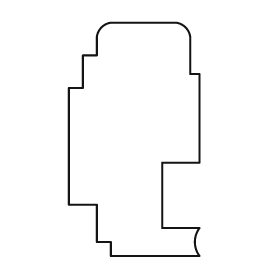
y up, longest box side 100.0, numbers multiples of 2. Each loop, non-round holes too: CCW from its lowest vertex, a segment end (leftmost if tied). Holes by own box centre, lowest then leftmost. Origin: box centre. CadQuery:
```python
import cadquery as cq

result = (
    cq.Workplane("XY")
    .moveTo(-10.0, -50.0)
    .lineTo(28.0, -50.0)
    .threePointArc((26.0, -44.0), (28.0, -38.0))
    .lineTo(12.0, -38.0)
    .lineTo(12.0, -10.0)
    .lineTo(28.0, -10.0)
    .lineTo(28.0, 28.0)
    .lineTo(24.0, 28.0)
    .lineTo(24.0, 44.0)
    .threePointArc((22.0, 48.0), (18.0, 50.0))
    .lineTo(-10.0, 50.0)
    .threePointArc((-14.0, 48.0), (-16.0, 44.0))
    .lineTo(-16.0, 36.0)
    .lineTo(-22.0, 36.0)
    .lineTo(-22.0, 22.0)
    .lineTo(-28.0, 22.0)
    .lineTo(-28.0, -28.0)
    .lineTo(-16.0, -28.0)
    .lineTo(-16.0, -44.0)
    .lineTo(-10.0, -44.0)
    .close()
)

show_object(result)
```